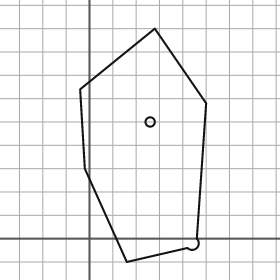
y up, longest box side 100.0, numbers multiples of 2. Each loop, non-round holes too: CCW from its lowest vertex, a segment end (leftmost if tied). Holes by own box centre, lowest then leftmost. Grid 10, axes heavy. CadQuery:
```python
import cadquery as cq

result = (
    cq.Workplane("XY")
    .moveTo(16.0, -10.0)
    .lineTo(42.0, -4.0)
    .threePointArc((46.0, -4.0), (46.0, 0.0))
    .lineTo(50.0, 58.0)
    .lineTo(28.0, 90.0)
    .lineTo(-4.0, 64.0)
    .lineTo(-2.0, 30.0)
    .close()
    .moveTo(26.0, 50.0)
    .circle(2.0)
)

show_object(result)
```